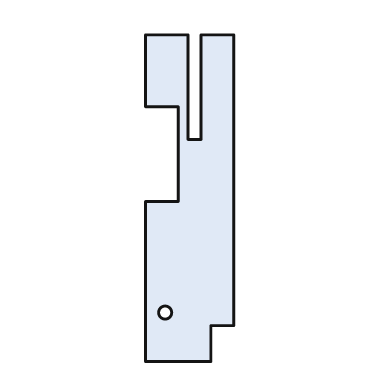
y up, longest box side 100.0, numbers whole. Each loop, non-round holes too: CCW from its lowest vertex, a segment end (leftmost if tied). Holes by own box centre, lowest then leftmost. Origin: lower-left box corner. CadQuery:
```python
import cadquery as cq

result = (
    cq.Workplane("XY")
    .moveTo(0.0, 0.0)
    .lineTo(20.0, 0.0)
    .lineTo(20.0, 11.0)
    .lineTo(27.0, 11.0)
    .lineTo(27.0, 100.0)
    .lineTo(17.0, 100.0)
    .lineTo(17.0, 68.0)
    .lineTo(13.0, 68.0)
    .lineTo(13.0, 100.0)
    .lineTo(0.0, 100.0)
    .lineTo(0.0, 78.0)
    .lineTo(10.0, 78.0)
    .lineTo(10.0, 49.0)
    .lineTo(0.0, 49.0)
    .close()
    .moveTo(6.0, 15.0)
    .circle(2.0)
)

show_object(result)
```